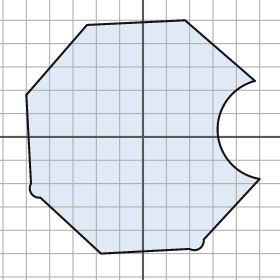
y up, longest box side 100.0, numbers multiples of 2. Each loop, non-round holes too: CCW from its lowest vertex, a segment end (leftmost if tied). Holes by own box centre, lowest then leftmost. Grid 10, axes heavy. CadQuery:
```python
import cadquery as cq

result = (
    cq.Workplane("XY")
    .moveTo(-18.0, -50.0)
    .lineTo(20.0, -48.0)
    .threePointArc((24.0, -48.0), (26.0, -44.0))
    .lineTo(50.0, -18.0)
    .threePointArc((32.0, 2.0), (48.0, 24.0))
    .lineTo(18.0, 50.0)
    .lineTo(-24.0, 48.0)
    .lineTo(-50.0, 18.0)
    .lineTo(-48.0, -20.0)
    .threePointArc((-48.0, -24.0), (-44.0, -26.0))
    .close()
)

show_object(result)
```